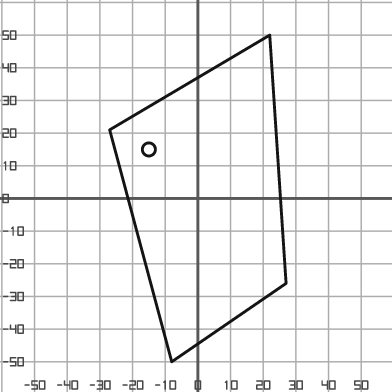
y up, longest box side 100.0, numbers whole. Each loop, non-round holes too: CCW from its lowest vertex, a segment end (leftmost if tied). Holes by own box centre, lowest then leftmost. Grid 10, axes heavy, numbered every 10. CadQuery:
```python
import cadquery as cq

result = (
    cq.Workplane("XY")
    .moveTo(-8.0, -50.0)
    .lineTo(27.0, -26.0)
    .lineTo(22.0, 50.0)
    .lineTo(-27.0, 21.0)
    .close()
    .moveTo(-15.0, 15.0)
    .circle(2.0)
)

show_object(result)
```